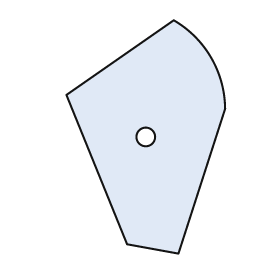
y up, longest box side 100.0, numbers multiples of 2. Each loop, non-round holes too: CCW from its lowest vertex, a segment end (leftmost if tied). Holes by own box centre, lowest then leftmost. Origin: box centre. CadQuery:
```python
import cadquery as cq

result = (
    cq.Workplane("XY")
    .moveTo(14.0, -50.0)
    .lineTo(34.0, 12.0)
    .threePointArc((28.0, 34.0), (12.0, 50.0))
    .lineTo(-34.0, 18.0)
    .lineTo(-8.0, -46.0)
    .close()
    .moveTo(0.0, 0.0)
    .circle(4.0)
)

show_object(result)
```